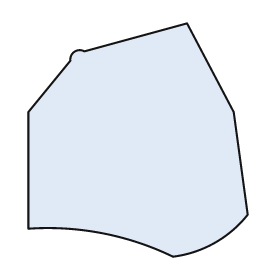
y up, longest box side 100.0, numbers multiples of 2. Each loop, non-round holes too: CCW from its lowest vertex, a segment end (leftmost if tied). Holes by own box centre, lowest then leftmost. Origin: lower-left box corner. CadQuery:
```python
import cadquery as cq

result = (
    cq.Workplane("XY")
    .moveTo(62.0, 0.0)
    .threePointArc((80.0, 6.0), (94.0, 18.0))
    .lineTo(88.0, 62.0)
    .lineTo(68.0, 100.0)
    .lineTo(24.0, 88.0)
    .threePointArc((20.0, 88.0), (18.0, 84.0))
    .lineTo(0.0, 62.0)
    .lineTo(0.0, 12.0)
    .threePointArc((32.0, 10.0), (62.0, 0.0))
    .close()
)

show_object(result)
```